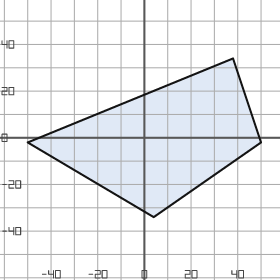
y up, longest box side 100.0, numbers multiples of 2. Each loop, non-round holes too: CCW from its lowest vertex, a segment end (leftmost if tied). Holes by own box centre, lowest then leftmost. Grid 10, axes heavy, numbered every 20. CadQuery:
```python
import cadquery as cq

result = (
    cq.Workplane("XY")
    .moveTo(4.0, -34.0)
    .lineTo(50.0, -2.0)
    .lineTo(38.0, 34.0)
    .lineTo(-50.0, -2.0)
    .close()
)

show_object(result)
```